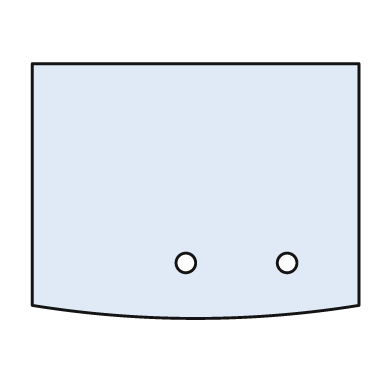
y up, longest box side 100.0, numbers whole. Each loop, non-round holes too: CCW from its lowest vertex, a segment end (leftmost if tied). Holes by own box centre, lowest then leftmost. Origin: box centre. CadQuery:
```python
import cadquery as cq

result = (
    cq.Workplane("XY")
    .moveTo(-50.0, -35.0)
    .threePointArc((0.0, -39.0), (50.0, -35.0))
    .lineTo(50.0, 39.0)
    .lineTo(-50.0, 39.0)
    .close()
    .moveTo(-3.0, -22.0)
    .circle(3.0)
    .moveTo(28.0, -22.0)
    .circle(3.0)
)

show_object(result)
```